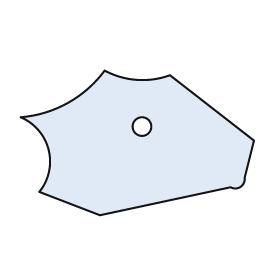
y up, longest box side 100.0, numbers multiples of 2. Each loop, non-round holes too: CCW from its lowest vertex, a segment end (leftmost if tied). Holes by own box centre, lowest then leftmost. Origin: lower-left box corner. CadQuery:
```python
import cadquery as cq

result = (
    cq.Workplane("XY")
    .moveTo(34.0, 0.0)
    .lineTo(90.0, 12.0)
    .threePointArc((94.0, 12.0), (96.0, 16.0))
    .lineTo(100.0, 32.0)
    .lineTo(64.0, 60.0)
    .threePointArc((50.0, 58.0), (36.0, 62.0))
    .threePointArc((20.0, 48.0), (0.0, 42.0))
    .threePointArc((12.0, 28.0), (8.0, 10.0))
    .close()
    .moveTo(52.0, 38.0)
    .circle(4.0)
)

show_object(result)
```